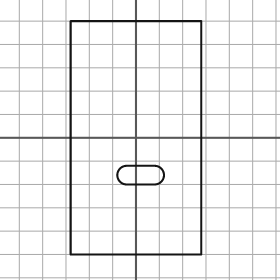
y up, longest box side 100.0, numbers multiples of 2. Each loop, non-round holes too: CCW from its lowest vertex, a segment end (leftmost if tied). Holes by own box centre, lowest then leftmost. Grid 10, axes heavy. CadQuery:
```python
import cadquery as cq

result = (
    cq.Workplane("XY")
    .moveTo(-28.0, -50.0)
    .lineTo(28.0, -50.0)
    .lineTo(28.0, 50.0)
    .lineTo(-28.0, 50.0)
    .close()
    .moveTo(-4.0, -20.0)
    .lineTo(8.0, -20.0)
    .threePointArc((12.0, -16.0), (8.0, -12.0))
    .lineTo(-4.0, -12.0)
    .threePointArc((-8.0, -16.0), (-4.0, -20.0))
    .close()
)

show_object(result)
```